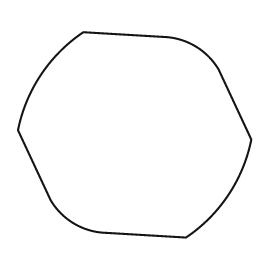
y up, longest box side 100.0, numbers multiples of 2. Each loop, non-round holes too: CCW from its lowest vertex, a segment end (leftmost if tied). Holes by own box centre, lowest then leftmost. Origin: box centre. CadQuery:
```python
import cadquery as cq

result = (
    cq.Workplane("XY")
    .moveTo(22.0, -44.0)
    .threePointArc((40.0, -26.0), (50.0, -2.0))
    .lineTo(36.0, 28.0)
    .threePointArc((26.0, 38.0), (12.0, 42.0))
    .lineTo(-22.0, 44.0)
    .threePointArc((-40.0, 26.0), (-50.0, 2.0))
    .lineTo(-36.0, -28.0)
    .threePointArc((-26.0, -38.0), (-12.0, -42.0))
    .close()
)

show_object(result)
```